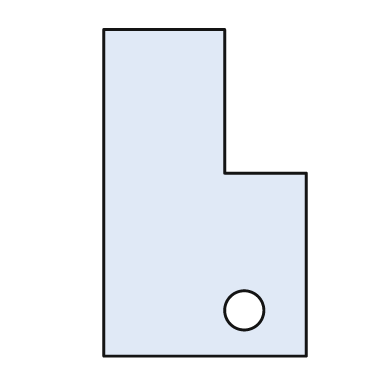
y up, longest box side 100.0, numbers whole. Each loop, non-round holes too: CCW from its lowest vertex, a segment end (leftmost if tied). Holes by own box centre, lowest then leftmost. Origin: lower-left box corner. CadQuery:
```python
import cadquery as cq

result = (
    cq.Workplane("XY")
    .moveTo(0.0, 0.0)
    .lineTo(62.0, 0.0)
    .lineTo(62.0, 56.0)
    .lineTo(37.0, 56.0)
    .lineTo(37.0, 100.0)
    .lineTo(0.0, 100.0)
    .close()
    .moveTo(43.0, 14.0)
    .circle(6.0)
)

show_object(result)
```